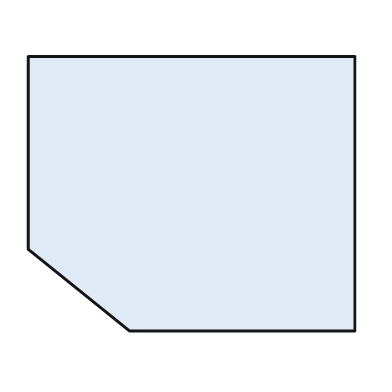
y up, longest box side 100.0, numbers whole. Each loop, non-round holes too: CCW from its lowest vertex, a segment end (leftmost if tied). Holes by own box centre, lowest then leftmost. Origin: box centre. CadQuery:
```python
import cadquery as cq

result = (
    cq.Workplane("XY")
    .moveTo(-19.0, -42.0)
    .lineTo(50.0, -42.0)
    .lineTo(50.0, 42.0)
    .lineTo(-50.0, 42.0)
    .lineTo(-50.0, -17.0)
    .close()
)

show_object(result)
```